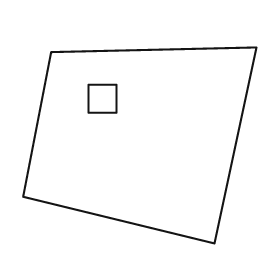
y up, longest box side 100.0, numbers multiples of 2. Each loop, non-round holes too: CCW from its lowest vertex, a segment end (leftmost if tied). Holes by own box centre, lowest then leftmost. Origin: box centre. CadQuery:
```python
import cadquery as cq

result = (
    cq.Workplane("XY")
    .moveTo(32.0, -42.0)
    .lineTo(50.0, 42.0)
    .lineTo(-38.0, 40.0)
    .lineTo(-50.0, -22.0)
    .close()
    .moveTo(-22.0, 14.0)
    .lineTo(-10.0, 14.0)
    .lineTo(-10.0, 26.0)
    .lineTo(-22.0, 26.0)
    .close()
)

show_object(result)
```